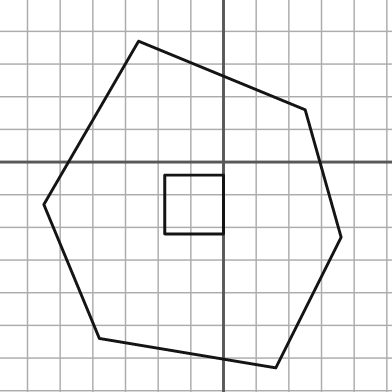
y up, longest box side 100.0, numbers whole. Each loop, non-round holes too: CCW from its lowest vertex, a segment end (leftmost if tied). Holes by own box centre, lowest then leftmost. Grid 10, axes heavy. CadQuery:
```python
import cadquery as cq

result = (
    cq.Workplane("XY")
    .moveTo(16.0, -63.0)
    .lineTo(36.0, -23.0)
    .lineTo(25.0, 16.0)
    .lineTo(-26.0, 37.0)
    .lineTo(-55.0, -13.0)
    .lineTo(-38.0, -54.0)
    .close()
    .moveTo(-18.0, -22.0)
    .lineTo(0.0, -22.0)
    .lineTo(0.0, -4.0)
    .lineTo(-18.0, -4.0)
    .close()
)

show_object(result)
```